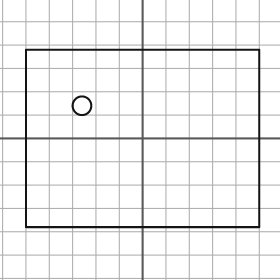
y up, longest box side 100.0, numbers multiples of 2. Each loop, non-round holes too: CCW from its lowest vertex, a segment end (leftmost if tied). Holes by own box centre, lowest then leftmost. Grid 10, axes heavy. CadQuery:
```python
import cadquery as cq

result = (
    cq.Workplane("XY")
    .moveTo(-50.0, -38.0)
    .lineTo(50.0, -38.0)
    .lineTo(50.0, 38.0)
    .lineTo(-50.0, 38.0)
    .close()
    .moveTo(-26.0, 14.0)
    .circle(4.0)
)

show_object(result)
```